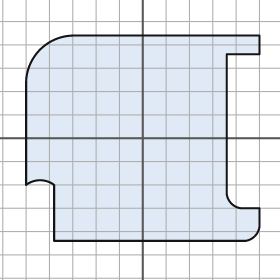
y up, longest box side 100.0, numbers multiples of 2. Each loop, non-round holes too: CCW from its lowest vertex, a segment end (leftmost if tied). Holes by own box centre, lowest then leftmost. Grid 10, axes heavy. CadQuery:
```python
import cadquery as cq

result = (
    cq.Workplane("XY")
    .moveTo(-38.0, -44.0)
    .lineTo(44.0, -44.0)
    .threePointArc((48.0, -42.0), (50.0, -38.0))
    .lineTo(50.0, -30.0)
    .lineTo(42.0, -30.0)
    .threePointArc((38.0, -28.0), (36.0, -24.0))
    .lineTo(36.0, 36.0)
    .lineTo(50.0, 36.0)
    .lineTo(50.0, 44.0)
    .lineTo(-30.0, 44.0)
    .threePointArc((-44.0, 38.0), (-50.0, 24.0))
    .lineTo(-50.0, -20.0)
    .threePointArc((-44.0, -18.0), (-38.0, -20.0))
    .close()
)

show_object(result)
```